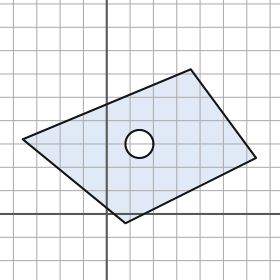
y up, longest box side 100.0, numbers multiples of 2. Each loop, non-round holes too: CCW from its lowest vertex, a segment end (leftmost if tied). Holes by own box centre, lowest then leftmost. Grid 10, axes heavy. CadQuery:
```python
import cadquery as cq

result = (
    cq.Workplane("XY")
    .moveTo(8.0, -4.0)
    .lineTo(64.0, 24.0)
    .lineTo(36.0, 62.0)
    .lineTo(-36.0, 32.0)
    .close()
    .moveTo(14.0, 30.0)
    .circle(6.0)
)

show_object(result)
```